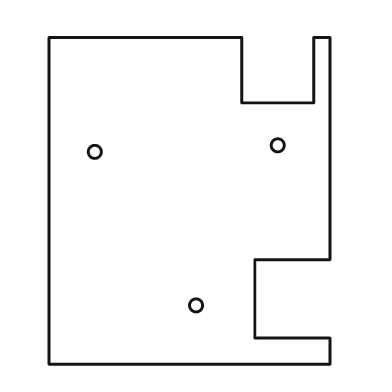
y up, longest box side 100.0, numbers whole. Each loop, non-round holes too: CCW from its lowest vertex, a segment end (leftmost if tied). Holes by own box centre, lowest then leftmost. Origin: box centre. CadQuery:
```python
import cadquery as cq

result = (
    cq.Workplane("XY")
    .moveTo(-43.0, -50.0)
    .lineTo(43.0, -50.0)
    .lineTo(43.0, -42.0)
    .lineTo(20.0, -42.0)
    .lineTo(20.0, -18.0)
    .lineTo(43.0, -18.0)
    .lineTo(43.0, 50.0)
    .lineTo(38.0, 50.0)
    .lineTo(38.0, 30.0)
    .lineTo(16.0, 30.0)
    .lineTo(16.0, 50.0)
    .lineTo(-43.0, 50.0)
    .close()
    .moveTo(2.0, -32.0)
    .circle(2.0)
    .moveTo(-29.0, 15.0)
    .circle(2.0)
    .moveTo(27.0, 17.0)
    .circle(2.0)
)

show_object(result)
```